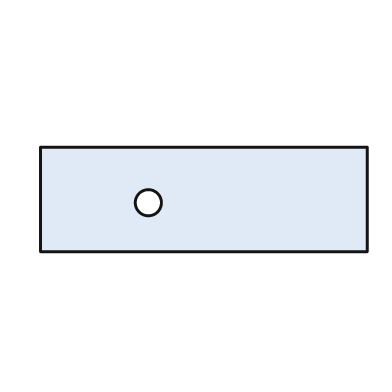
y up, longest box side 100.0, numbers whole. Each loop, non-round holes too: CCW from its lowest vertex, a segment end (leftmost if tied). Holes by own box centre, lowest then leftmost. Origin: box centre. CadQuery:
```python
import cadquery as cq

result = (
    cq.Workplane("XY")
    .moveTo(-50.0, -16.0)
    .lineTo(50.0, -16.0)
    .lineTo(50.0, 16.0)
    .lineTo(-50.0, 16.0)
    .close()
    .moveTo(-17.0, -1.0)
    .circle(4.0)
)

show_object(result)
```